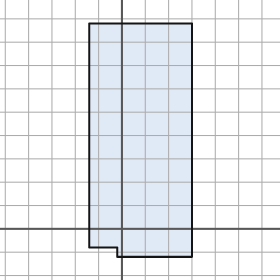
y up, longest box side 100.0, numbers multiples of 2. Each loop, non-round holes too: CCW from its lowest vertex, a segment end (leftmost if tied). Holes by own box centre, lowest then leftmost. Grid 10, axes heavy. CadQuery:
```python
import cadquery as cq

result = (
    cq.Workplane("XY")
    .moveTo(-2.0, -12.0)
    .lineTo(30.0, -12.0)
    .lineTo(30.0, 88.0)
    .lineTo(-14.0, 88.0)
    .lineTo(-14.0, -8.0)
    .lineTo(-2.0, -8.0)
    .close()
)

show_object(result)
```